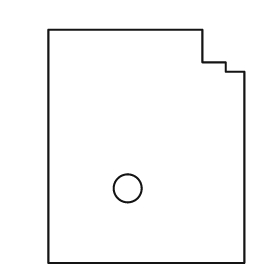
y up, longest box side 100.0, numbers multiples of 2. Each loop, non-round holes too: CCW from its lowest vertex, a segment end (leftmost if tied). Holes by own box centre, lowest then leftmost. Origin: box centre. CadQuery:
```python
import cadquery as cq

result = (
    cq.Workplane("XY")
    .moveTo(-42.0, -50.0)
    .lineTo(42.0, -50.0)
    .lineTo(42.0, 32.0)
    .lineTo(34.0, 32.0)
    .lineTo(34.0, 36.0)
    .lineTo(24.0, 36.0)
    .lineTo(24.0, 50.0)
    .lineTo(-42.0, 50.0)
    .close()
    .moveTo(-8.0, -18.0)
    .circle(6.0)
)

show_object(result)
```